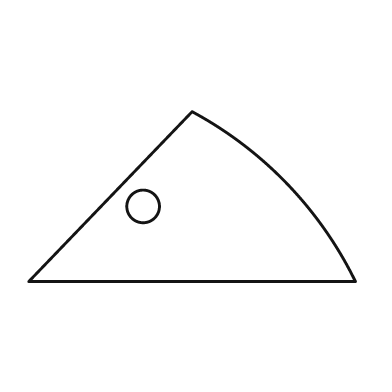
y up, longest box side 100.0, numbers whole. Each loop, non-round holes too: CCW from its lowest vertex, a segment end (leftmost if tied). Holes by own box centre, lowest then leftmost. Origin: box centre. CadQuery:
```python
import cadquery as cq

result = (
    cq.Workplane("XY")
    .moveTo(-50.0, -26.0)
    .lineTo(50.0, -26.0)
    .threePointArc((29.0, 4.0), (0.0, 26.0))
    .close()
    .moveTo(-15.0, -3.0)
    .circle(5.0)
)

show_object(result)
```